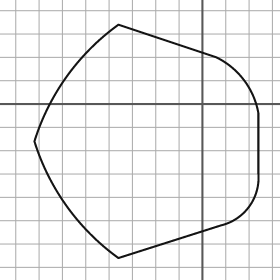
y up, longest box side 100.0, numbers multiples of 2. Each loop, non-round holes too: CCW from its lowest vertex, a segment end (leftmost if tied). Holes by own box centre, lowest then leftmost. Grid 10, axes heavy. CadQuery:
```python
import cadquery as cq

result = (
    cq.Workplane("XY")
    .moveTo(-36.0, -66.0)
    .lineTo(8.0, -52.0)
    .threePointArc((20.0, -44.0), (24.0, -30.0))
    .lineTo(24.0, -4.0)
    .threePointArc((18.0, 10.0), (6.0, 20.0))
    .lineTo(-36.0, 34.0)
    .threePointArc((-58.0, 12.0), (-72.0, -16.0))
    .threePointArc((-58.0, -44.0), (-36.0, -66.0))
    .close()
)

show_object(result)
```